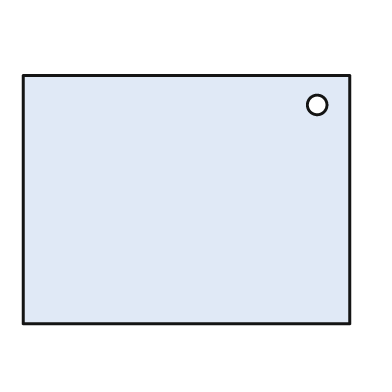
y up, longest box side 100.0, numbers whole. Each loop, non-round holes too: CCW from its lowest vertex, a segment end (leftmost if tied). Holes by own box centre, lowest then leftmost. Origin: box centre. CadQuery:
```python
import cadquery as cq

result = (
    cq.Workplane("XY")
    .moveTo(-50.0, -38.0)
    .lineTo(50.0, -38.0)
    .lineTo(50.0, 38.0)
    .lineTo(-50.0, 38.0)
    .close()
    .moveTo(40.0, 29.0)
    .circle(3.0)
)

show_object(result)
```